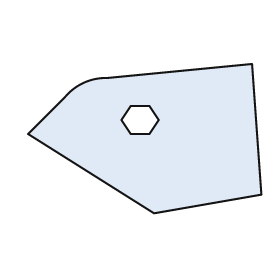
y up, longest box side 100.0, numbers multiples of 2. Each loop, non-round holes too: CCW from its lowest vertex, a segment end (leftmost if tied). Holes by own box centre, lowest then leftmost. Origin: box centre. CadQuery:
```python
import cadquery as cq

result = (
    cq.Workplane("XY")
    .moveTo(4.0, -32.0)
    .lineTo(50.0, -24.0)
    .lineTo(46.0, 32.0)
    .lineTo(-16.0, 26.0)
    .threePointArc((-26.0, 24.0), (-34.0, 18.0))
    .lineTo(-50.0, 2.0)
    .close()
    .moveTo(-6.0, 2.0)
    .lineTo(2.0, 2.0)
    .lineTo(6.0, 8.0)
    .lineTo(2.0, 14.0)
    .lineTo(-6.0, 14.0)
    .lineTo(-10.0, 8.0)
    .close()
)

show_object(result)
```